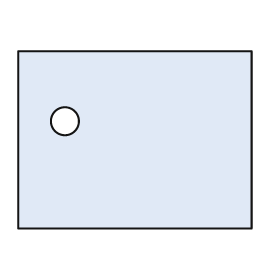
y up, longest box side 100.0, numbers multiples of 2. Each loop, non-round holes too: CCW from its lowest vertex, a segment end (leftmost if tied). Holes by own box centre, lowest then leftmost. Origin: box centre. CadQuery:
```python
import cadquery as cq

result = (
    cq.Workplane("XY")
    .moveTo(-50.0, -38.0)
    .lineTo(50.0, -38.0)
    .lineTo(50.0, 38.0)
    .lineTo(-50.0, 38.0)
    .close()
    .moveTo(-30.0, 8.0)
    .circle(6.0)
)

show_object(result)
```